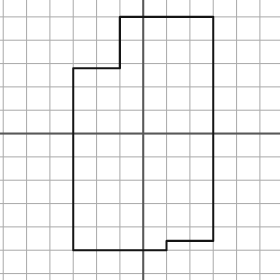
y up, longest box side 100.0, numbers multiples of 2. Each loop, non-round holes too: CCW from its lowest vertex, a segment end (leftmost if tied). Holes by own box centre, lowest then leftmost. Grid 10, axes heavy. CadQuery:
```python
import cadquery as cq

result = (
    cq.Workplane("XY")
    .moveTo(-30.0, -50.0)
    .lineTo(10.0, -50.0)
    .lineTo(10.0, -46.0)
    .lineTo(30.0, -46.0)
    .lineTo(30.0, 50.0)
    .lineTo(-10.0, 50.0)
    .lineTo(-10.0, 28.0)
    .lineTo(-30.0, 28.0)
    .close()
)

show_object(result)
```